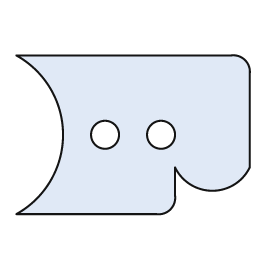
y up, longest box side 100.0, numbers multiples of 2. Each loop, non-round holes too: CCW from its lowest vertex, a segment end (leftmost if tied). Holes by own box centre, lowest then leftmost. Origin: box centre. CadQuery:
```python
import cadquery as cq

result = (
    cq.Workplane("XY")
    .moveTo(-50.0, -34.0)
    .lineTo(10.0, -34.0)
    .threePointArc((16.0, -32.0), (18.0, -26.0))
    .lineTo(18.0, -14.0)
    .threePointArc((34.0, -24.0), (50.0, -14.0))
    .lineTo(50.0, 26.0)
    .threePointArc((48.0, 32.0), (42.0, 34.0))
    .lineTo(-50.0, 34.0)
    .threePointArc((-30.0, 0.0), (-50.0, -34.0))
    .close()
    .moveTo(-12.0, 0.0)
    .circle(6.0)
    .moveTo(12.0, 0.0)
    .circle(6.0)
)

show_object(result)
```